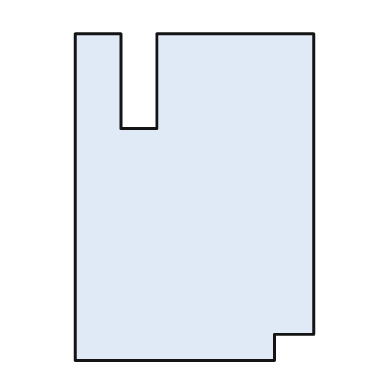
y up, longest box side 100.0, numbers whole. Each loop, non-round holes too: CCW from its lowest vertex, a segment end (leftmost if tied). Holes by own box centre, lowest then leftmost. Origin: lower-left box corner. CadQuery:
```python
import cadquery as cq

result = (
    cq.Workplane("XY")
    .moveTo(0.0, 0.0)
    .lineTo(61.0, 0.0)
    .lineTo(61.0, 8.0)
    .lineTo(73.0, 8.0)
    .lineTo(73.0, 100.0)
    .lineTo(25.0, 100.0)
    .lineTo(25.0, 71.0)
    .lineTo(14.0, 71.0)
    .lineTo(14.0, 100.0)
    .lineTo(0.0, 100.0)
    .close()
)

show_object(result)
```